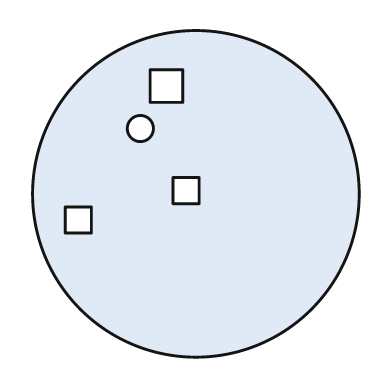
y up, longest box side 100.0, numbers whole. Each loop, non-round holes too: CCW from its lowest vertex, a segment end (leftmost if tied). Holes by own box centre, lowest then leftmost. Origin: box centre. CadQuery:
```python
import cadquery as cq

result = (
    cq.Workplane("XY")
    .moveTo(0.0, 0.0)
    .circle(50.0)
    .moveTo(-40.0, -12.0)
    .lineTo(-32.0, -12.0)
    .lineTo(-32.0, -4.0)
    .lineTo(-40.0, -4.0)
    .close()
    .moveTo(-7.0, -3.0)
    .lineTo(1.0, -3.0)
    .lineTo(1.0, 5.0)
    .lineTo(-7.0, 5.0)
    .close()
    .moveTo(-17.0, 20.0)
    .circle(4.0)
    .moveTo(-14.0, 28.0)
    .lineTo(-4.0, 28.0)
    .lineTo(-4.0, 38.0)
    .lineTo(-14.0, 38.0)
    .close()
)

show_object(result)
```